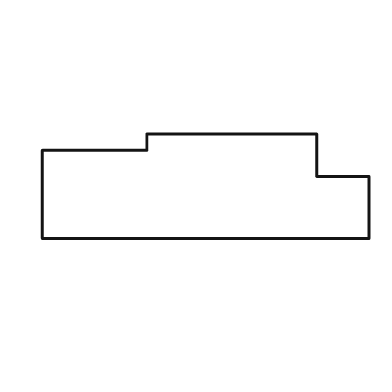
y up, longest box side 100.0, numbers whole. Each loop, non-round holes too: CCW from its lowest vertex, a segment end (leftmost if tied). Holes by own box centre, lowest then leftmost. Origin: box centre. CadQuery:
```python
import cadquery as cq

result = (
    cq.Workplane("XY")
    .moveTo(-50.0, -16.0)
    .lineTo(50.0, -16.0)
    .lineTo(50.0, 3.0)
    .lineTo(34.0, 3.0)
    .lineTo(34.0, 16.0)
    .lineTo(-18.0, 16.0)
    .lineTo(-18.0, 11.0)
    .lineTo(-50.0, 11.0)
    .close()
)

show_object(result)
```